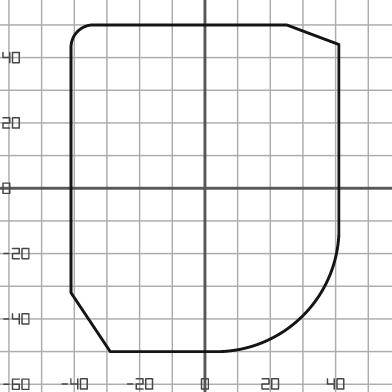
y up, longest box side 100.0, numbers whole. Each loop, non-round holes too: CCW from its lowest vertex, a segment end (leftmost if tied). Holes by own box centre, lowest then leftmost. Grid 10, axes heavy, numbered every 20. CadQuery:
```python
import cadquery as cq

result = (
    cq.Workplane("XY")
    .moveTo(-29.0, -50.0)
    .lineTo(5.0, -50.0)
    .threePointArc((30.0, -39.0), (41.0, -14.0))
    .lineTo(41.0, 44.0)
    .lineTo(25.0, 50.0)
    .lineTo(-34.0, 50.0)
    .threePointArc((-39.0, 48.0), (-41.0, 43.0))
    .lineTo(-41.0, -32.0)
    .close()
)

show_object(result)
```